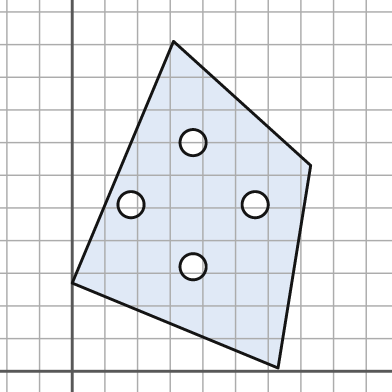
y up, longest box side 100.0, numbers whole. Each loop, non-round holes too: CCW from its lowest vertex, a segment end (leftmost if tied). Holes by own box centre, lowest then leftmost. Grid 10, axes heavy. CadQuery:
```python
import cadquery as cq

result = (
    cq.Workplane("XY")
    .moveTo(63.0, 1.0)
    .lineTo(73.0, 63.0)
    .lineTo(31.0, 101.0)
    .lineTo(0.0, 27.0)
    .close()
    .moveTo(37.0, 32.0)
    .circle(4.0)
    .moveTo(18.0, 51.0)
    .circle(4.0)
    .moveTo(56.0, 51.0)
    .circle(4.0)
    .moveTo(37.0, 70.0)
    .circle(4.0)
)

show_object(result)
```